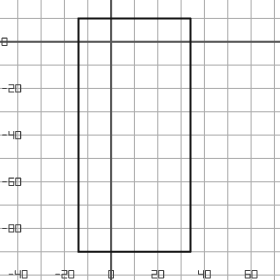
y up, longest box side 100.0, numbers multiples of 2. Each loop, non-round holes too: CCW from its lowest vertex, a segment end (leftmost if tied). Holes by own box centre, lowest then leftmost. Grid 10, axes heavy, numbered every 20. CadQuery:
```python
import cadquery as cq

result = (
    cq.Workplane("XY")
    .moveTo(-14.0, -90.0)
    .lineTo(34.0, -90.0)
    .lineTo(34.0, 10.0)
    .lineTo(-14.0, 10.0)
    .close()
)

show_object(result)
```